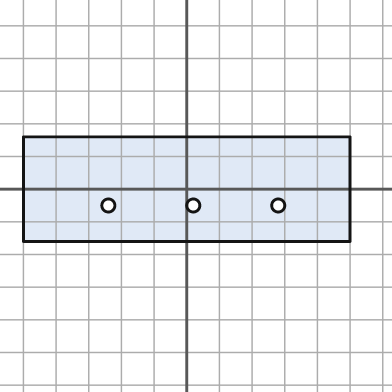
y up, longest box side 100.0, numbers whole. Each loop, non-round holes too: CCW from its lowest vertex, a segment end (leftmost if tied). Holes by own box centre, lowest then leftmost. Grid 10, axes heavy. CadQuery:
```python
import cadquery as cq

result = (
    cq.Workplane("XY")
    .moveTo(-50.0, -16.0)
    .lineTo(50.0, -16.0)
    .lineTo(50.0, 16.0)
    .lineTo(-50.0, 16.0)
    .close()
    .moveTo(-24.0, -5.0)
    .circle(2.0)
    .moveTo(2.0, -5.0)
    .circle(2.0)
    .moveTo(28.0, -5.0)
    .circle(2.0)
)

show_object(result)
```